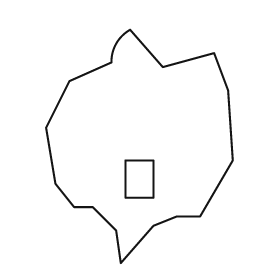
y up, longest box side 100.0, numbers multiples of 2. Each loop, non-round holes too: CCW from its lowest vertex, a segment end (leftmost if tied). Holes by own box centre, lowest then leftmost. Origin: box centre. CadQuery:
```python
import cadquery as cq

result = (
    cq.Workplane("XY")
    .moveTo(-8.0, -50.0)
    .lineTo(6.0, -34.0)
    .lineTo(16.0, -30.0)
    .lineTo(26.0, -30.0)
    .lineTo(40.0, -6.0)
    .lineTo(38.0, 24.0)
    .lineTo(32.0, 40.0)
    .lineTo(10.0, 34.0)
    .lineTo(-4.0, 50.0)
    .threePointArc((-10.0, 44.0), (-12.0, 36.0))
    .lineTo(-30.0, 28.0)
    .lineTo(-40.0, 8.0)
    .lineTo(-36.0, -16.0)
    .lineTo(-28.0, -26.0)
    .lineTo(-20.0, -26.0)
    .lineTo(-10.0, -36.0)
    .close()
    .moveTo(-6.0, -22.0)
    .lineTo(6.0, -22.0)
    .lineTo(6.0, -6.0)
    .lineTo(-6.0, -6.0)
    .close()
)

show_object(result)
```